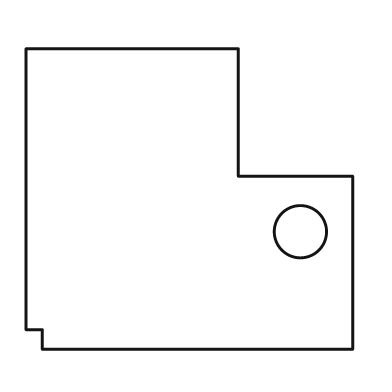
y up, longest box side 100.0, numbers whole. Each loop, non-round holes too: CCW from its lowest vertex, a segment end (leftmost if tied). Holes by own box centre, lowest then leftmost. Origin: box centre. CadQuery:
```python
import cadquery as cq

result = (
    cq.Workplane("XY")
    .moveTo(-45.0, -46.0)
    .lineTo(50.0, -46.0)
    .lineTo(50.0, 7.0)
    .lineTo(15.0, 7.0)
    .lineTo(15.0, 46.0)
    .lineTo(-50.0, 46.0)
    .lineTo(-50.0, -40.0)
    .lineTo(-45.0, -40.0)
    .close()
    .moveTo(34.0, -10.0)
    .circle(8.0)
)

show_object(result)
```